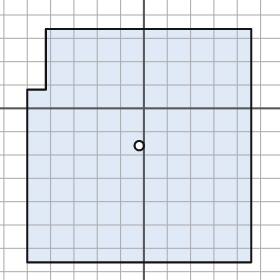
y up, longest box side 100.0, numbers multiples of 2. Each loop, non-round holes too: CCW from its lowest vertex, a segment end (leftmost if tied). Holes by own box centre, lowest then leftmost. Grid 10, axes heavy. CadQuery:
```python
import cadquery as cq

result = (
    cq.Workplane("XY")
    .moveTo(-50.0, -66.0)
    .lineTo(46.0, -66.0)
    .lineTo(46.0, 34.0)
    .lineTo(-42.0, 34.0)
    .lineTo(-42.0, 8.0)
    .lineTo(-50.0, 8.0)
    .close()
    .moveTo(-2.0, -16.0)
    .circle(2.0)
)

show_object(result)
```